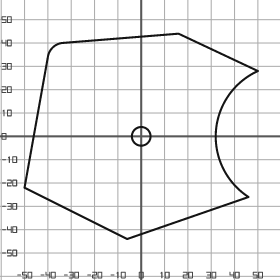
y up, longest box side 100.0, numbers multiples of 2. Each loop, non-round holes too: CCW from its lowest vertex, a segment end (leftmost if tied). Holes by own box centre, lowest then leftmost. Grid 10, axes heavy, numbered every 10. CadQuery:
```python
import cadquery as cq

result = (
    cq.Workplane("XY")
    .moveTo(-6.0, -44.0)
    .lineTo(46.0, -26.0)
    .threePointArc((32.0, 2.0), (50.0, 28.0))
    .lineTo(16.0, 44.0)
    .lineTo(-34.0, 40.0)
    .threePointArc((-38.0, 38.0), (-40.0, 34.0))
    .lineTo(-50.0, -22.0)
    .close()
    .moveTo(0.0, 0.0)
    .circle(4.0)
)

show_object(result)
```